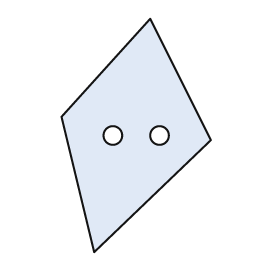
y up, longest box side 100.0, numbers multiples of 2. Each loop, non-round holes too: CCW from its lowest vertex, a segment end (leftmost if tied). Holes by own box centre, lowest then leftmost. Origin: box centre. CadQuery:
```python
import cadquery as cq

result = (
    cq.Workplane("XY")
    .moveTo(-18.0, -50.0)
    .lineTo(32.0, -2.0)
    .lineTo(6.0, 50.0)
    .lineTo(-32.0, 8.0)
    .close()
    .moveTo(-10.0, 0.0)
    .circle(4.0)
    .moveTo(10.0, 0.0)
    .circle(4.0)
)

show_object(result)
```